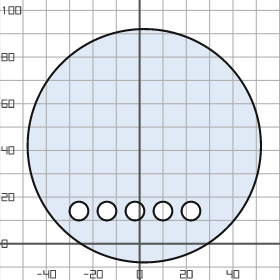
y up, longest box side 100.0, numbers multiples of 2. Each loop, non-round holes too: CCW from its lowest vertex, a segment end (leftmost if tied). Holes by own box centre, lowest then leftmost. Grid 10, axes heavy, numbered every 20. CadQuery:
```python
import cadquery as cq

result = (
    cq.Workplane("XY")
    .moveTo(2.0, 42.0)
    .circle(50.0)
    .moveTo(-26.0, 14.0)
    .circle(4.0)
    .moveTo(-14.0, 14.0)
    .circle(4.0)
    .moveTo(-2.0, 14.0)
    .circle(4.0)
    .moveTo(10.0, 14.0)
    .circle(4.0)
    .moveTo(22.0, 14.0)
    .circle(4.0)
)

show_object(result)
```